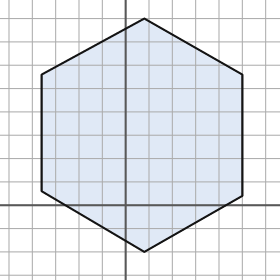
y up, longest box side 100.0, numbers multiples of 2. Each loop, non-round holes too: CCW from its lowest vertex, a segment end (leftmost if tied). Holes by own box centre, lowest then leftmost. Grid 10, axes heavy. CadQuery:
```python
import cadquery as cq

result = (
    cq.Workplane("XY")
    .moveTo(8.0, -20.0)
    .lineTo(50.0, 4.0)
    .lineTo(50.0, 56.0)
    .lineTo(8.0, 80.0)
    .lineTo(-36.0, 56.0)
    .lineTo(-36.0, 6.0)
    .close()
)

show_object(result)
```